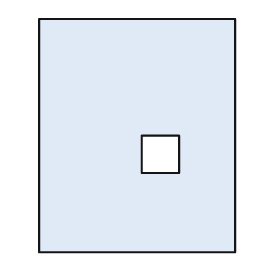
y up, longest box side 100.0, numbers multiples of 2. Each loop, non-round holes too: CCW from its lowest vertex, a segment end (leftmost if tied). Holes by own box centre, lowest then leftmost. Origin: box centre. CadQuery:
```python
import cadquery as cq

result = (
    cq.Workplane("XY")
    .moveTo(-42.0, -50.0)
    .lineTo(42.0, -50.0)
    .lineTo(42.0, 50.0)
    .lineTo(-42.0, 50.0)
    .close()
    .moveTo(2.0, -16.0)
    .lineTo(18.0, -16.0)
    .lineTo(18.0, 0.0)
    .lineTo(2.0, 0.0)
    .close()
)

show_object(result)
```